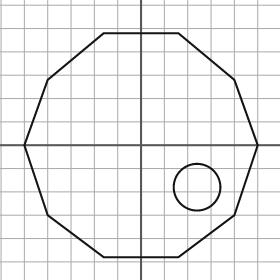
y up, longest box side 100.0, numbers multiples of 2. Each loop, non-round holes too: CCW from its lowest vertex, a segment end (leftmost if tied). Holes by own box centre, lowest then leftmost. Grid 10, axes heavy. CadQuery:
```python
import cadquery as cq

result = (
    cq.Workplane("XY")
    .moveTo(-16.0, -48.0)
    .lineTo(16.0, -48.0)
    .lineTo(40.0, -30.0)
    .lineTo(50.0, 0.0)
    .lineTo(40.0, 28.0)
    .lineTo(16.0, 48.0)
    .lineTo(-16.0, 48.0)
    .lineTo(-40.0, 28.0)
    .lineTo(-50.0, 0.0)
    .lineTo(-40.0, -30.0)
    .close()
    .moveTo(24.0, -18.0)
    .circle(10.0)
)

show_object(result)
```